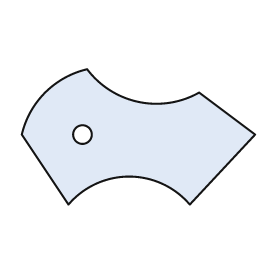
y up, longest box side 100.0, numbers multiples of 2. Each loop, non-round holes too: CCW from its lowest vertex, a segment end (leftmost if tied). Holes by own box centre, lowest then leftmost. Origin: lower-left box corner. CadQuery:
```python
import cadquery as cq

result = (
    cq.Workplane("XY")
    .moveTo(20.0, 0.0)
    .threePointArc((46.0, 12.0), (72.0, 0.0))
    .lineTo(100.0, 30.0)
    .lineTo(76.0, 48.0)
    .threePointArc((50.0, 44.0), (28.0, 58.0))
    .threePointArc((10.0, 48.0), (0.0, 30.0))
    .close()
    .moveTo(26.0, 30.0)
    .circle(4.0)
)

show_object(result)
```